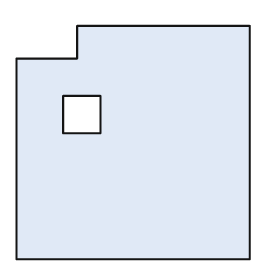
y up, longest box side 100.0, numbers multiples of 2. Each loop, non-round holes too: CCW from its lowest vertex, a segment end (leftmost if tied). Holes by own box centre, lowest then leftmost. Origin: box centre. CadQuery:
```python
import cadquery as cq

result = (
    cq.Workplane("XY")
    .moveTo(-50.0, -50.0)
    .lineTo(50.0, -50.0)
    .lineTo(50.0, 50.0)
    .lineTo(-24.0, 50.0)
    .lineTo(-24.0, 36.0)
    .lineTo(-50.0, 36.0)
    .close()
    .moveTo(-30.0, 4.0)
    .lineTo(-14.0, 4.0)
    .lineTo(-14.0, 20.0)
    .lineTo(-30.0, 20.0)
    .close()
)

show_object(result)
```